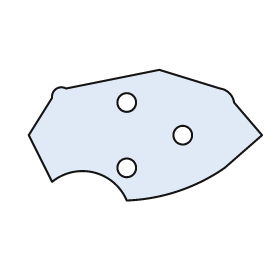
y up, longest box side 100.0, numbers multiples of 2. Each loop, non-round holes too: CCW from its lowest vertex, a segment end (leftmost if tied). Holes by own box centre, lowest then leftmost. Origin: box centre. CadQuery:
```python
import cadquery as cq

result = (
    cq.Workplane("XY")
    .moveTo(-8.0, -28.0)
    .threePointArc((14.0, -24.0), (34.0, -14.0))
    .lineTo(50.0, 0.0)
    .lineTo(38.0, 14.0)
    .threePointArc((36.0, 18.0), (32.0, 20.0))
    .lineTo(6.0, 28.0)
    .lineTo(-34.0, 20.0)
    .threePointArc((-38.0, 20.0), (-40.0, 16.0))
    .lineTo(-50.0, 0.0)
    .lineTo(-40.0, -20.0)
    .threePointArc((-22.0, -16.0), (-8.0, -28.0))
    .close()
    .moveTo(-8.0, -14.0)
    .circle(4.0)
    .moveTo(16.0, 0.0)
    .circle(4.0)
    .moveTo(-8.0, 14.0)
    .circle(4.0)
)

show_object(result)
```